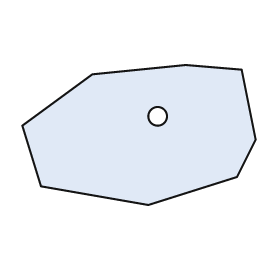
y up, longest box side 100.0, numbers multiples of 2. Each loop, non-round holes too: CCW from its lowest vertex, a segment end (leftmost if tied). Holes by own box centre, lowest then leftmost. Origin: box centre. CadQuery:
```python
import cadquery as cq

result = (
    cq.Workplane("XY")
    .moveTo(4.0, -30.0)
    .lineTo(42.0, -18.0)
    .lineTo(50.0, -2.0)
    .lineTo(44.0, 28.0)
    .lineTo(20.0, 30.0)
    .lineTo(-20.0, 26.0)
    .lineTo(-50.0, 4.0)
    .lineTo(-42.0, -22.0)
    .close()
    .moveTo(8.0, 8.0)
    .circle(4.0)
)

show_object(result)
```